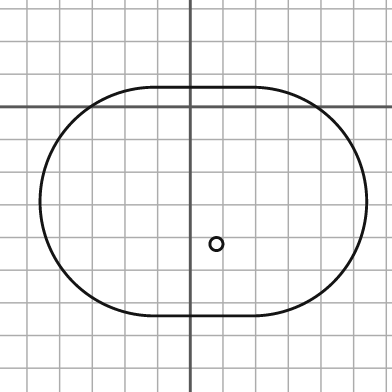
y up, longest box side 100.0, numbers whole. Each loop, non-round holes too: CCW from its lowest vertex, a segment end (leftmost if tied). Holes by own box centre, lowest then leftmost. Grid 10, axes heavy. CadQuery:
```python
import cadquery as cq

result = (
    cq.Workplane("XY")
    .moveTo(-11.0, -64.0)
    .lineTo(19.0, -64.0)
    .threePointArc((54.0, -29.0), (19.0, 6.0))
    .lineTo(-11.0, 6.0)
    .threePointArc((-46.0, -29.0), (-11.0, -64.0))
    .close()
    .moveTo(8.0, -42.0)
    .circle(2.0)
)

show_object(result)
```